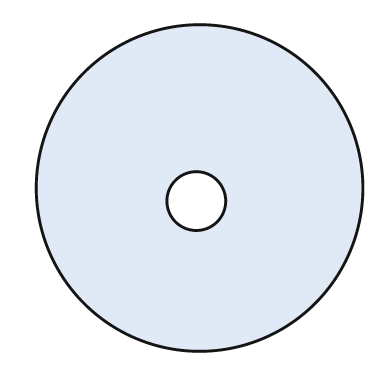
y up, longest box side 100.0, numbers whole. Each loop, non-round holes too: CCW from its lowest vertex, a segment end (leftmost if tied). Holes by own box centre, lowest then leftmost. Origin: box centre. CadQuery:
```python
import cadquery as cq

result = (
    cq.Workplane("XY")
    .moveTo(0.0, 0.0)
    .circle(50.0)
    .moveTo(-1.0, -4.0)
    .circle(9.0)
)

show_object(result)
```